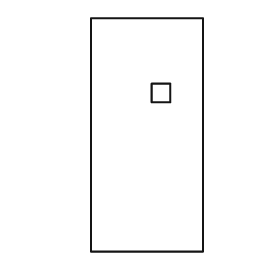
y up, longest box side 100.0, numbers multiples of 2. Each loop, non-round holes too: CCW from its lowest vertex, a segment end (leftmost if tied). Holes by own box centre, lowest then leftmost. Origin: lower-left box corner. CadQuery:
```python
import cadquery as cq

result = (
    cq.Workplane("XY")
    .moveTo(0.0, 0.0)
    .lineTo(48.0, 0.0)
    .lineTo(48.0, 100.0)
    .lineTo(0.0, 100.0)
    .close()
    .moveTo(26.0, 64.0)
    .lineTo(34.0, 64.0)
    .lineTo(34.0, 72.0)
    .lineTo(26.0, 72.0)
    .close()
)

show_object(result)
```